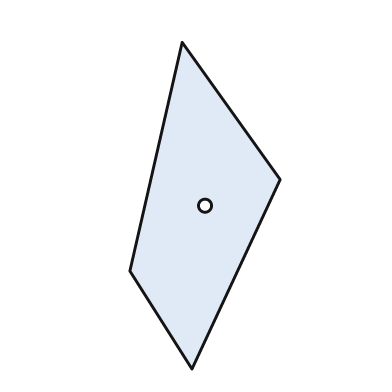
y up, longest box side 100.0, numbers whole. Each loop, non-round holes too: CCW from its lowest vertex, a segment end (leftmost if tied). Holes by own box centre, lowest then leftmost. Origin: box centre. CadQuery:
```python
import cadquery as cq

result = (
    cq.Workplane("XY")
    .moveTo(-4.0, -50.0)
    .lineTo(23.0, 8.0)
    .lineTo(-7.0, 50.0)
    .lineTo(-23.0, -20.0)
    .close()
    .moveTo(0.0, 0.0)
    .circle(2.0)
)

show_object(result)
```